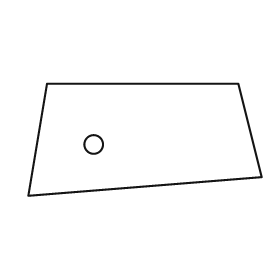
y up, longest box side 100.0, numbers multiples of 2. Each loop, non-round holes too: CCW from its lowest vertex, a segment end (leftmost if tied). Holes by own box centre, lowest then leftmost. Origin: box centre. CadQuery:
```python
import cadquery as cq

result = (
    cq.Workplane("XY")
    .moveTo(-50.0, -24.0)
    .lineTo(50.0, -16.0)
    .lineTo(40.0, 24.0)
    .lineTo(-42.0, 24.0)
    .close()
    .moveTo(-22.0, -2.0)
    .circle(4.0)
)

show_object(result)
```